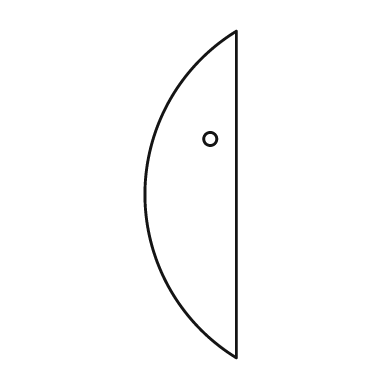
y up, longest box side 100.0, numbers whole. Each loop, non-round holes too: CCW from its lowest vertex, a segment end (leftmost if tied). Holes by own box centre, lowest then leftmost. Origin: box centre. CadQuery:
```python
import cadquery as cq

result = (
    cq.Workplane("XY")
    .moveTo(14.0, -50.0)
    .lineTo(14.0, 50.0)
    .threePointArc((-14.0, 0.0), (14.0, -50.0))
    .close()
    .moveTo(6.0, 17.0)
    .circle(2.0)
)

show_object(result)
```